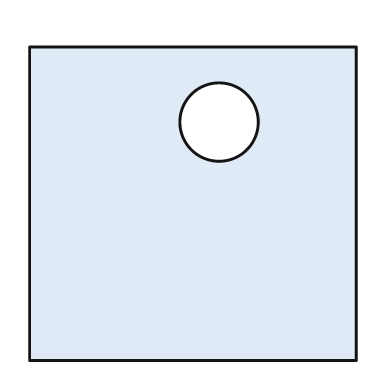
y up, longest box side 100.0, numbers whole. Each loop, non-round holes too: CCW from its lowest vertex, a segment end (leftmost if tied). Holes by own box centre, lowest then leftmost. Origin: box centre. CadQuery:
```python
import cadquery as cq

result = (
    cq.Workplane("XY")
    .moveTo(-50.0, -48.0)
    .lineTo(50.0, -48.0)
    .lineTo(50.0, 48.0)
    .lineTo(-50.0, 48.0)
    .close()
    .moveTo(8.0, 25.0)
    .circle(12.0)
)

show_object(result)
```